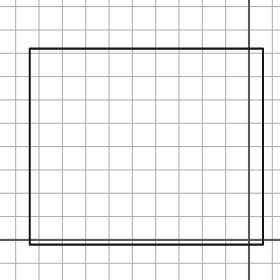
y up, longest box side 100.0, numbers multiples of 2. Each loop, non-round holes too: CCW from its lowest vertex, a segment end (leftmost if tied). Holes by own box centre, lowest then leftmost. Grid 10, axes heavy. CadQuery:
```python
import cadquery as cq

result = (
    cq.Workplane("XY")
    .moveTo(-94.0, -2.0)
    .lineTo(6.0, -2.0)
    .lineTo(6.0, 82.0)
    .lineTo(-94.0, 82.0)
    .close()
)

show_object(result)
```